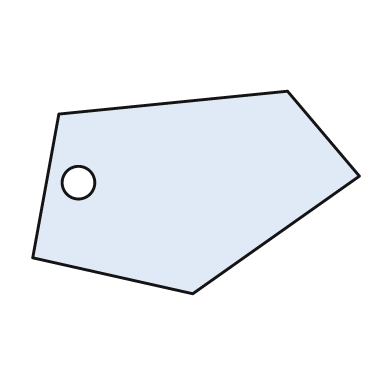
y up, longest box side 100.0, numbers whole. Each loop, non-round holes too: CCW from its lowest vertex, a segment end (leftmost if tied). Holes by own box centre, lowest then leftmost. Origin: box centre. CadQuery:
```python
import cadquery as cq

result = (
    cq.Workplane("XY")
    .moveTo(-1.0, -31.0)
    .lineTo(50.0, 5.0)
    .lineTo(28.0, 31.0)
    .lineTo(-42.0, 24.0)
    .lineTo(-50.0, -20.0)
    .close()
    .moveTo(-36.0, 3.0)
    .circle(5.0)
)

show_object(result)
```